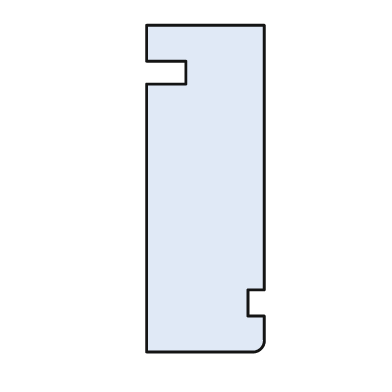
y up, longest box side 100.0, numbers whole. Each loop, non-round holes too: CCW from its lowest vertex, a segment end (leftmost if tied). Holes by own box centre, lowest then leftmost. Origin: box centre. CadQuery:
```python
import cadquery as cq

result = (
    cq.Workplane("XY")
    .moveTo(-18.0, -50.0)
    .lineTo(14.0, -50.0)
    .threePointArc((17.0, -49.0), (18.0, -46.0))
    .lineTo(18.0, -39.0)
    .lineTo(13.0, -39.0)
    .lineTo(13.0, -31.0)
    .lineTo(18.0, -31.0)
    .lineTo(18.0, 50.0)
    .lineTo(-18.0, 50.0)
    .lineTo(-18.0, 39.0)
    .lineTo(-6.0, 39.0)
    .lineTo(-6.0, 32.0)
    .lineTo(-18.0, 32.0)
    .close()
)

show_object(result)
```